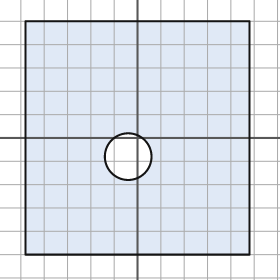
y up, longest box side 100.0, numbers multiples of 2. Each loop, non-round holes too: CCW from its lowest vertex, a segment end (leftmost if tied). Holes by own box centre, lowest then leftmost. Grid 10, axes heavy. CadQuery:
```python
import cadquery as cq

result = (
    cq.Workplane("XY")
    .moveTo(-48.0, -50.0)
    .lineTo(48.0, -50.0)
    .lineTo(48.0, 50.0)
    .lineTo(-48.0, 50.0)
    .close()
    .moveTo(-4.0, -8.0)
    .circle(10.0)
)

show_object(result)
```